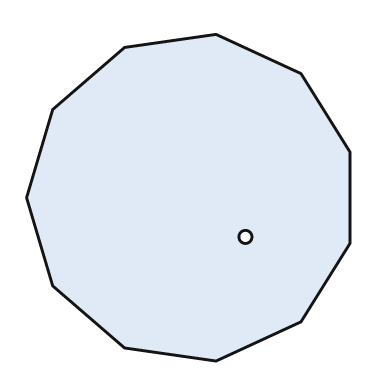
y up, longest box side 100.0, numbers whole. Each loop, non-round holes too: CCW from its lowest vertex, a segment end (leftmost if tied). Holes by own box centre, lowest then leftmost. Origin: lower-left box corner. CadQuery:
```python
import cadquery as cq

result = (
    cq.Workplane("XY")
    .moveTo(58.0, 0.0)
    .lineTo(84.0, 12.0)
    .lineTo(99.0, 36.0)
    .lineTo(99.0, 64.0)
    .lineTo(84.0, 88.0)
    .lineTo(58.0, 100.0)
    .lineTo(30.0, 96.0)
    .lineTo(8.0, 77.0)
    .lineTo(0.0, 50.0)
    .lineTo(8.0, 23.0)
    .lineTo(30.0, 4.0)
    .close()
    .moveTo(67.0, 38.0)
    .circle(2.0)
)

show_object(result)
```